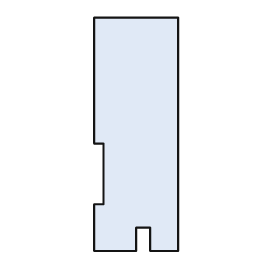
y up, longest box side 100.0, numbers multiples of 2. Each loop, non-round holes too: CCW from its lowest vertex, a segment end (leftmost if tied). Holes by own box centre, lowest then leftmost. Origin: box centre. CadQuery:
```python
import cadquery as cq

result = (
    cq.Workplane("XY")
    .moveTo(-18.0, -50.0)
    .lineTo(0.0, -50.0)
    .lineTo(0.0, -40.0)
    .lineTo(6.0, -40.0)
    .lineTo(6.0, -50.0)
    .lineTo(18.0, -50.0)
    .lineTo(18.0, 50.0)
    .lineTo(-18.0, 50.0)
    .lineTo(-18.0, -4.0)
    .lineTo(-14.0, -4.0)
    .lineTo(-14.0, -30.0)
    .lineTo(-18.0, -30.0)
    .close()
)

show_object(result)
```